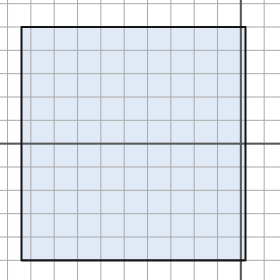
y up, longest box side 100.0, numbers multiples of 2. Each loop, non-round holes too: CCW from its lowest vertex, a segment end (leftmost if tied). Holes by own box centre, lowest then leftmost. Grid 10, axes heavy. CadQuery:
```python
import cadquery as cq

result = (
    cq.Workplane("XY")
    .moveTo(-94.0, -50.0)
    .lineTo(2.0, -50.0)
    .lineTo(2.0, 50.0)
    .lineTo(-94.0, 50.0)
    .close()
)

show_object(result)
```